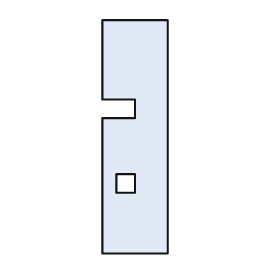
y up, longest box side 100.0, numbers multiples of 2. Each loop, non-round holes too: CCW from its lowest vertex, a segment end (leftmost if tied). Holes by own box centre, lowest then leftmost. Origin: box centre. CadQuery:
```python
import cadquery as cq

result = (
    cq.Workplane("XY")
    .moveTo(-14.0, -50.0)
    .lineTo(14.0, -50.0)
    .lineTo(14.0, 50.0)
    .lineTo(-14.0, 50.0)
    .lineTo(-14.0, 16.0)
    .lineTo(0.0, 16.0)
    .lineTo(0.0, 8.0)
    .lineTo(-14.0, 8.0)
    .close()
    .moveTo(-8.0, -24.0)
    .lineTo(0.0, -24.0)
    .lineTo(0.0, -16.0)
    .lineTo(-8.0, -16.0)
    .close()
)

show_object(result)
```